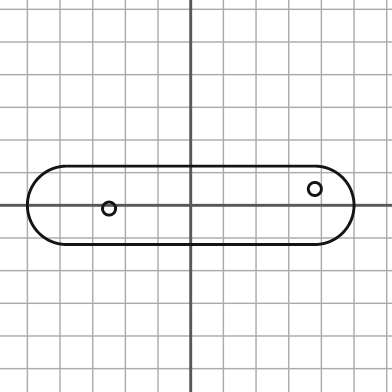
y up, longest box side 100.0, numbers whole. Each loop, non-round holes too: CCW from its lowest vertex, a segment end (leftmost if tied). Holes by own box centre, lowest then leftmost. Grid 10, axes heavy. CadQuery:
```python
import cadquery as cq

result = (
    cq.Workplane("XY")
    .moveTo(-38.0, -12.0)
    .lineTo(38.0, -12.0)
    .threePointArc((50.0, 0.0), (38.0, 12.0))
    .lineTo(-38.0, 12.0)
    .threePointArc((-50.0, 0.0), (-38.0, -12.0))
    .close()
    .moveTo(-25.0, -1.0)
    .circle(2.0)
    .moveTo(38.0, 5.0)
    .circle(2.0)
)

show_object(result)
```